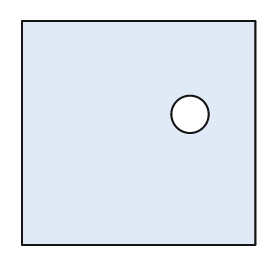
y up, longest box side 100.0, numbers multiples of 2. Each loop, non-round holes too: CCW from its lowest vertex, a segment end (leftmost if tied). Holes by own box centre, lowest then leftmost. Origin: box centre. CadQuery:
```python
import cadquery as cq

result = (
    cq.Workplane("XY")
    .moveTo(-50.0, -48.0)
    .lineTo(50.0, -48.0)
    .lineTo(50.0, 48.0)
    .lineTo(-50.0, 48.0)
    .close()
    .moveTo(22.0, 8.0)
    .circle(8.0)
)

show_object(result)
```